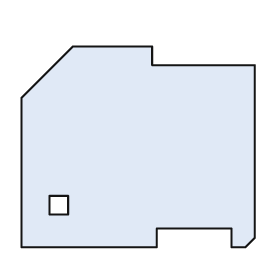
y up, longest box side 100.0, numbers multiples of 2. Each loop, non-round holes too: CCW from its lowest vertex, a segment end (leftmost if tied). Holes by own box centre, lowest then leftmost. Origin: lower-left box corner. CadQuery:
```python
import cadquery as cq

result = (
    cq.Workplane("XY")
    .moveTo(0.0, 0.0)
    .lineTo(58.0, 0.0)
    .lineTo(58.0, 8.0)
    .lineTo(90.0, 8.0)
    .lineTo(90.0, 0.0)
    .lineTo(96.0, 0.0)
    .lineTo(100.0, 4.0)
    .lineTo(100.0, 78.0)
    .lineTo(56.0, 78.0)
    .lineTo(56.0, 86.0)
    .lineTo(22.0, 86.0)
    .lineTo(0.0, 64.0)
    .close()
    .moveTo(12.0, 14.0)
    .lineTo(20.0, 14.0)
    .lineTo(20.0, 22.0)
    .lineTo(12.0, 22.0)
    .close()
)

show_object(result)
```